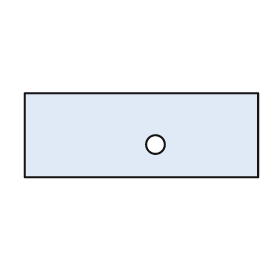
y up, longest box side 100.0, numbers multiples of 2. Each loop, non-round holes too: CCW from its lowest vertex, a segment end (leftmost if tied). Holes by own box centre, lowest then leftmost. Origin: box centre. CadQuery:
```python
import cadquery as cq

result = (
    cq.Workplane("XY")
    .moveTo(-50.0, -18.0)
    .lineTo(50.0, -18.0)
    .lineTo(50.0, 18.0)
    .lineTo(-50.0, 18.0)
    .close()
    .moveTo(6.0, -4.0)
    .circle(4.0)
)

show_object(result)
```